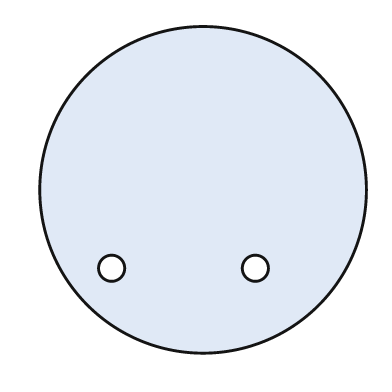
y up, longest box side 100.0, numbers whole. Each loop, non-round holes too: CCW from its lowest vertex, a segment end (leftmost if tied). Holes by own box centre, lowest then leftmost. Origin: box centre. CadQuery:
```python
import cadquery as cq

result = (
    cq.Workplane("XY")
    .moveTo(0.0, 0.0)
    .circle(50.0)
    .moveTo(-28.0, -24.0)
    .circle(4.0)
    .moveTo(16.0, -24.0)
    .circle(4.0)
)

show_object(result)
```